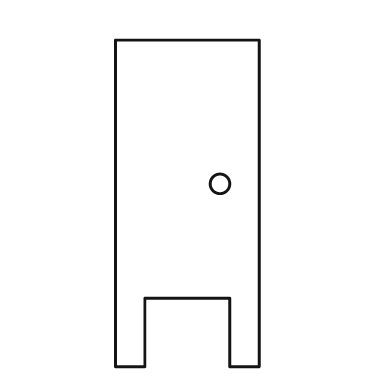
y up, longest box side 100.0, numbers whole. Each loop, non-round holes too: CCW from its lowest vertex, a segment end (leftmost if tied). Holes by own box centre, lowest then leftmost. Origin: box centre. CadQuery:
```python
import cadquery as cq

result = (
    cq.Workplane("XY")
    .moveTo(-22.0, -50.0)
    .lineTo(-13.0, -50.0)
    .lineTo(-13.0, -29.0)
    .lineTo(13.0, -29.0)
    .lineTo(13.0, -50.0)
    .lineTo(22.0, -50.0)
    .lineTo(22.0, 50.0)
    .lineTo(-22.0, 50.0)
    .close()
    .moveTo(10.0, 6.0)
    .circle(3.0)
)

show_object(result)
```